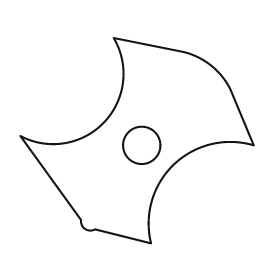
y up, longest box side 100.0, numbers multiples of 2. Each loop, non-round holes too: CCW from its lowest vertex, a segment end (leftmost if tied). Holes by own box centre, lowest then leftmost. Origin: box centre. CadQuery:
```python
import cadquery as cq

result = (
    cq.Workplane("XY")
    .moveTo(6.0, -44.0)
    .threePointArc((16.0, -10.0), (50.0, -2.0))
    .lineTo(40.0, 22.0)
    .threePointArc((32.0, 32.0), (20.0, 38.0))
    .lineTo(-10.0, 44.0)
    .threePointArc((-14.0, 8.0), (-50.0, 2.0))
    .lineTo(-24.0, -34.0)
    .threePointArc((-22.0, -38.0), (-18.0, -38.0))
    .close()
    .moveTo(2.0, -2.0)
    .circle(8.0)
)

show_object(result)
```